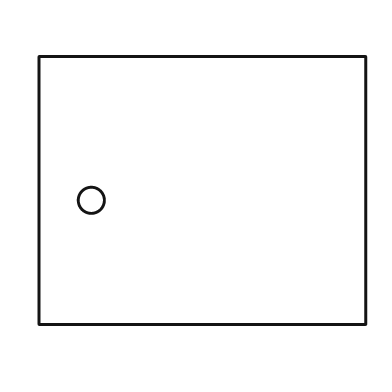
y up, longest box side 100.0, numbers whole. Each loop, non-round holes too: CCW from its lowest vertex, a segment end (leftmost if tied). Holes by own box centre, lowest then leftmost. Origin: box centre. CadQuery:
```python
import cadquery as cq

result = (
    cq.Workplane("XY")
    .moveTo(-50.0, -41.0)
    .lineTo(50.0, -41.0)
    .lineTo(50.0, 41.0)
    .lineTo(-50.0, 41.0)
    .close()
    .moveTo(-34.0, -3.0)
    .circle(4.0)
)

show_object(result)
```